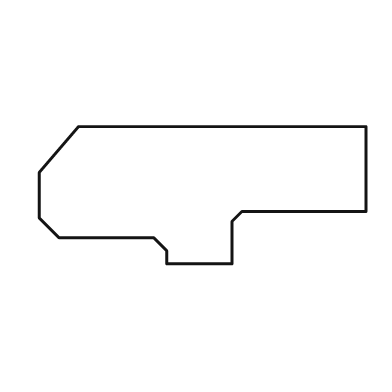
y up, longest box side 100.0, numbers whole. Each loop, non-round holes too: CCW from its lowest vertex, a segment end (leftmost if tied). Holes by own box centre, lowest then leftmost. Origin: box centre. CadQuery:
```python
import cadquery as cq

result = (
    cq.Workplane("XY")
    .moveTo(-11.0, -21.0)
    .lineTo(9.0, -21.0)
    .lineTo(9.0, -8.0)
    .lineTo(12.0, -5.0)
    .lineTo(50.0, -5.0)
    .lineTo(50.0, 21.0)
    .lineTo(-38.0, 21.0)
    .lineTo(-50.0, 7.0)
    .lineTo(-50.0, -7.0)
    .lineTo(-44.0, -13.0)
    .lineTo(-15.0, -13.0)
    .lineTo(-11.0, -17.0)
    .close()
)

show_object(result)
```